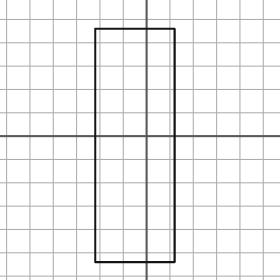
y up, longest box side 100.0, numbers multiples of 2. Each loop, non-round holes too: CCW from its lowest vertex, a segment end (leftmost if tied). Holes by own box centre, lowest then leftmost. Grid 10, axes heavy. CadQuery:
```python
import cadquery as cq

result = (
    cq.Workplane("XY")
    .moveTo(-22.0, -54.0)
    .lineTo(12.0, -54.0)
    .lineTo(12.0, 46.0)
    .lineTo(-22.0, 46.0)
    .close()
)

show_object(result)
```